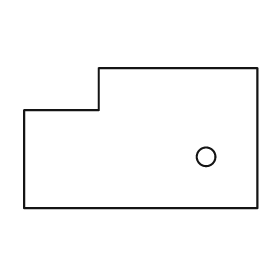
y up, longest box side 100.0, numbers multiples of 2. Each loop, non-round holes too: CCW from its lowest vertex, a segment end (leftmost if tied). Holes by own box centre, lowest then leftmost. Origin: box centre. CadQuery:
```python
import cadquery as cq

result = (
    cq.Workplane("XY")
    .moveTo(-50.0, -30.0)
    .lineTo(50.0, -30.0)
    .lineTo(50.0, 30.0)
    .lineTo(-18.0, 30.0)
    .lineTo(-18.0, 12.0)
    .lineTo(-50.0, 12.0)
    .close()
    .moveTo(28.0, -8.0)
    .circle(4.0)
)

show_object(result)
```